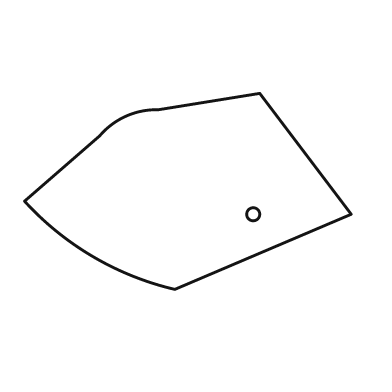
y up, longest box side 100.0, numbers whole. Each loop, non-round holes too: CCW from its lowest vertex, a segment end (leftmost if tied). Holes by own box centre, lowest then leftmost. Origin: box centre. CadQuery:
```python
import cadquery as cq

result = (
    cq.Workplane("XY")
    .moveTo(-4.0, -30.0)
    .lineTo(50.0, -7.0)
    .lineTo(22.0, 30.0)
    .lineTo(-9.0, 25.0)
    .threePointArc((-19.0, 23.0), (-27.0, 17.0))
    .lineTo(-50.0, -3.0)
    .threePointArc((-29.0, -20.0), (-4.0, -30.0))
    .close()
    .moveTo(20.0, -7.0)
    .circle(2.0)
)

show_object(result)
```